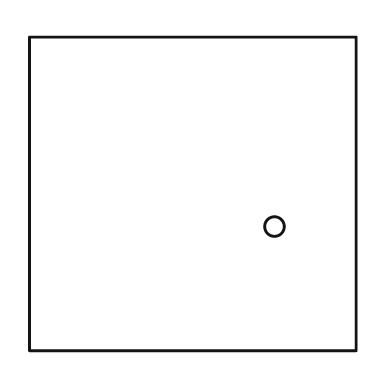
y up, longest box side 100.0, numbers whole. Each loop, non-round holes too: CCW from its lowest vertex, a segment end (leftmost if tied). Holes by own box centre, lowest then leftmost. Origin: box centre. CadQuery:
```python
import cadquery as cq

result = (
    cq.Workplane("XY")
    .moveTo(-50.0, -48.0)
    .lineTo(50.0, -48.0)
    .lineTo(50.0, 48.0)
    .lineTo(-50.0, 48.0)
    .close()
    .moveTo(25.0, -10.0)
    .circle(3.0)
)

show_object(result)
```